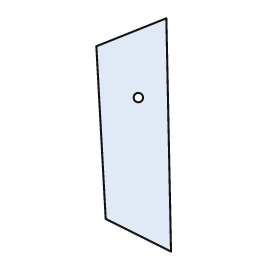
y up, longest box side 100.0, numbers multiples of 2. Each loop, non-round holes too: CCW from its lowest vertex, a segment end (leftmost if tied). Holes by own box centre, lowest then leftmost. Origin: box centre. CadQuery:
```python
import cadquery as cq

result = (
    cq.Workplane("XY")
    .moveTo(16.0, -50.0)
    .lineTo(14.0, 50.0)
    .lineTo(-16.0, 38.0)
    .lineTo(-12.0, -36.0)
    .close()
    .moveTo(2.0, 16.0)
    .circle(2.0)
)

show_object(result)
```